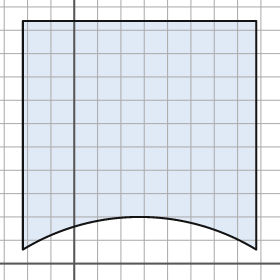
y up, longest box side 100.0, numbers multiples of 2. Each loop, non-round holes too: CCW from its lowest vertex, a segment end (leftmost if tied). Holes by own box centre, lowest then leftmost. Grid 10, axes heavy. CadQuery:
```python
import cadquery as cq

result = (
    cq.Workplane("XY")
    .moveTo(-22.0, 6.0)
    .threePointArc((28.0, 20.0), (78.0, 6.0))
    .lineTo(78.0, 104.0)
    .lineTo(-22.0, 104.0)
    .close()
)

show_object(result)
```